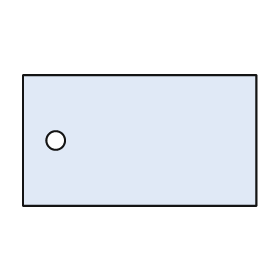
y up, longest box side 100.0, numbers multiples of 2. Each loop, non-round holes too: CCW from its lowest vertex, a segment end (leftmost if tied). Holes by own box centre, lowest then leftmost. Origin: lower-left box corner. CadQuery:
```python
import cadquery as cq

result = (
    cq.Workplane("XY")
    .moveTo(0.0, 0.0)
    .lineTo(100.0, 0.0)
    .lineTo(100.0, 56.0)
    .lineTo(0.0, 56.0)
    .close()
    .moveTo(14.0, 28.0)
    .circle(4.0)
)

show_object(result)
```